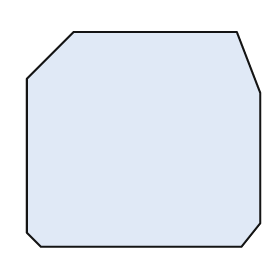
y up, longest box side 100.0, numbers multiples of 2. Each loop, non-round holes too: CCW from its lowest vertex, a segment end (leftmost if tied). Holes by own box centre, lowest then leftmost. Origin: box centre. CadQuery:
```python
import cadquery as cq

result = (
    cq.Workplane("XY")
    .moveTo(-44.0, -46.0)
    .lineTo(42.0, -46.0)
    .lineTo(50.0, -36.0)
    .lineTo(50.0, 20.0)
    .lineTo(40.0, 46.0)
    .lineTo(-30.0, 46.0)
    .lineTo(-50.0, 26.0)
    .lineTo(-50.0, -40.0)
    .close()
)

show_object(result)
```